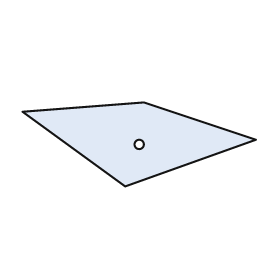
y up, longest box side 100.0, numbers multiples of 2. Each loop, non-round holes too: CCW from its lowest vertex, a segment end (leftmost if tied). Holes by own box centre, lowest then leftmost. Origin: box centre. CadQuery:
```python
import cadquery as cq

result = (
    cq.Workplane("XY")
    .moveTo(-6.0, -18.0)
    .lineTo(50.0, 2.0)
    .lineTo(2.0, 18.0)
    .lineTo(-50.0, 14.0)
    .close()
    .moveTo(0.0, 0.0)
    .circle(2.0)
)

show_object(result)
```